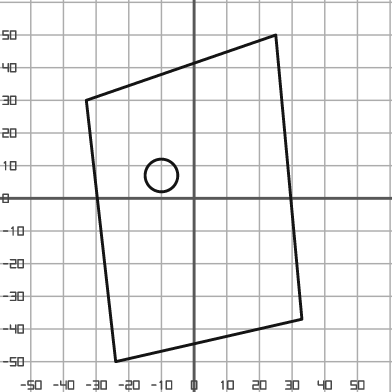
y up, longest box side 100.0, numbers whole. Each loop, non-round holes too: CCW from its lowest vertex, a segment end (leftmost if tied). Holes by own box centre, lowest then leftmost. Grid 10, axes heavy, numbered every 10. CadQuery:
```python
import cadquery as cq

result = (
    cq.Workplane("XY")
    .moveTo(-24.0, -50.0)
    .lineTo(33.0, -37.0)
    .lineTo(25.0, 50.0)
    .lineTo(-33.0, 30.0)
    .close()
    .moveTo(-10.0, 7.0)
    .circle(5.0)
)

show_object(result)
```